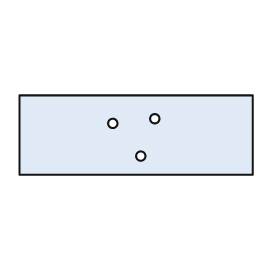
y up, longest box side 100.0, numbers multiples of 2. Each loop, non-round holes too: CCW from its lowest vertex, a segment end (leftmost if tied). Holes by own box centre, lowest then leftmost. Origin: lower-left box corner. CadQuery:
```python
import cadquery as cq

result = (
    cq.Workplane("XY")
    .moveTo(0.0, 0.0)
    .lineTo(100.0, 0.0)
    .lineTo(100.0, 34.0)
    .lineTo(0.0, 34.0)
    .close()
    .moveTo(52.0, 8.0)
    .circle(2.0)
    .moveTo(40.0, 22.0)
    .circle(2.0)
    .moveTo(58.0, 24.0)
    .circle(2.0)
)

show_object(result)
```